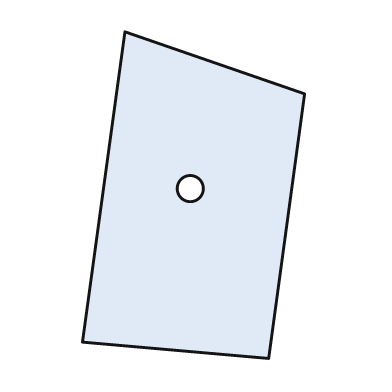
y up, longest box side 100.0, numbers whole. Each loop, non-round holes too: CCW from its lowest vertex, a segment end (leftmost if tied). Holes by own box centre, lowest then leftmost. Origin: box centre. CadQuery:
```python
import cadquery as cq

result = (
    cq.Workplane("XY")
    .moveTo(23.0, -50.0)
    .lineTo(34.0, 31.0)
    .lineTo(-21.0, 50.0)
    .lineTo(-34.0, -45.0)
    .close()
    .moveTo(-1.0, 2.0)
    .circle(4.0)
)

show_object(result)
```